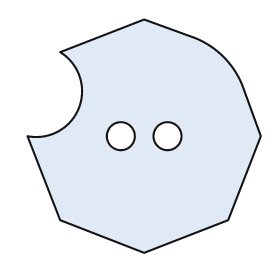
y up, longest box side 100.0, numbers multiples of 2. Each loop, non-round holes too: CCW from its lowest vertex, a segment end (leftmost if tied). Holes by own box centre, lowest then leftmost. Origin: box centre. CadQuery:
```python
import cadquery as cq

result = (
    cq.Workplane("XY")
    .moveTo(0.0, -50.0)
    .lineTo(36.0, -36.0)
    .lineTo(50.0, 0.0)
    .lineTo(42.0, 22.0)
    .threePointArc((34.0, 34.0), (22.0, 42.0))
    .lineTo(0.0, 50.0)
    .lineTo(-36.0, 36.0)
    .threePointArc((-28.0, 12.0), (-50.0, 0.0))
    .lineTo(-36.0, -36.0)
    .close()
    .moveTo(-10.0, 0.0)
    .circle(6.0)
    .moveTo(10.0, 0.0)
    .circle(6.0)
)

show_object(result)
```